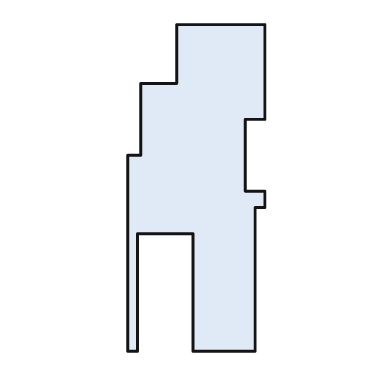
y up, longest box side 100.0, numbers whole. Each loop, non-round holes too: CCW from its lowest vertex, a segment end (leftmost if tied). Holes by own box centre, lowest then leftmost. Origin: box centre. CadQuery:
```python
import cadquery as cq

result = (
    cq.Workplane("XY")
    .moveTo(-21.0, -50.0)
    .lineTo(-18.0, -50.0)
    .lineTo(-18.0, -14.0)
    .lineTo(-1.0, -14.0)
    .lineTo(-1.0, -50.0)
    .lineTo(18.0, -50.0)
    .lineTo(18.0, -6.0)
    .lineTo(21.0, -6.0)
    .lineTo(21.0, -1.0)
    .lineTo(15.0, -1.0)
    .lineTo(15.0, 21.0)
    .lineTo(21.0, 21.0)
    .lineTo(21.0, 50.0)
    .lineTo(-6.0, 50.0)
    .lineTo(-6.0, 32.0)
    .lineTo(-17.0, 32.0)
    .lineTo(-17.0, 10.0)
    .lineTo(-21.0, 10.0)
    .close()
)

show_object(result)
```